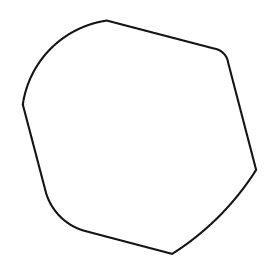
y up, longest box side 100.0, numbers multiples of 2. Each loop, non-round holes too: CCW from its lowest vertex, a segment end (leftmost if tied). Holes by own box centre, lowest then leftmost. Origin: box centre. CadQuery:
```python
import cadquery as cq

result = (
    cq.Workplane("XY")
    .moveTo(14.0, -50.0)
    .threePointArc((34.0, -34.0), (50.0, -14.0))
    .lineTo(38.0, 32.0)
    .threePointArc((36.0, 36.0), (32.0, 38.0))
    .lineTo(-14.0, 50.0)
    .threePointArc((-38.0, 38.0), (-50.0, 14.0))
    .lineTo(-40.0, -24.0)
    .threePointArc((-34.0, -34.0), (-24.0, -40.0))
    .close()
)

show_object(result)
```